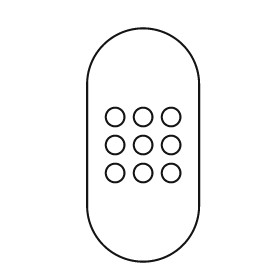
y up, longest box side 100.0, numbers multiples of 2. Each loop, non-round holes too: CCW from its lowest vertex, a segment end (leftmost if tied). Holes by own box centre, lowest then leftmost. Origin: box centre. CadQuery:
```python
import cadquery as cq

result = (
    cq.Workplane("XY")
    .moveTo(-24.0, -26.0)
    .threePointArc((0.0, -50.0), (24.0, -26.0))
    .lineTo(24.0, 26.0)
    .threePointArc((0.0, 50.0), (-24.0, 26.0))
    .close()
    .moveTo(-12.0, -12.0)
    .circle(4.0)
    .moveTo(0.0, -12.0)
    .circle(4.0)
    .moveTo(12.0, -12.0)
    .circle(4.0)
    .moveTo(-12.0, 0.0)
    .circle(4.0)
    .moveTo(0.0, 0.0)
    .circle(4.0)
    .moveTo(12.0, 0.0)
    .circle(4.0)
    .moveTo(-12.0, 12.0)
    .circle(4.0)
    .moveTo(0.0, 12.0)
    .circle(4.0)
    .moveTo(12.0, 12.0)
    .circle(4.0)
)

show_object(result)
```